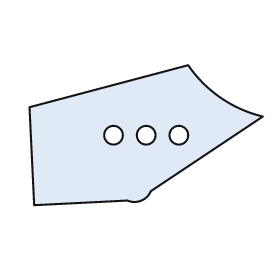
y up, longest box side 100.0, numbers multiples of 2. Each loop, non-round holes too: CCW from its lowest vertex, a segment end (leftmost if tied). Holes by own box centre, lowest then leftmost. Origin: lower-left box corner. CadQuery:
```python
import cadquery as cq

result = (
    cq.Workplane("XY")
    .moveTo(2.0, 0.0)
    .lineTo(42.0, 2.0)
    .threePointArc((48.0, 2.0), (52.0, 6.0))
    .lineTo(100.0, 38.0)
    .threePointArc((82.0, 46.0), (68.0, 60.0))
    .lineTo(0.0, 42.0)
    .close()
    .moveTo(36.0, 30.0)
    .circle(4.0)
    .moveTo(50.0, 30.0)
    .circle(4.0)
    .moveTo(64.0, 30.0)
    .circle(4.0)
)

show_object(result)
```